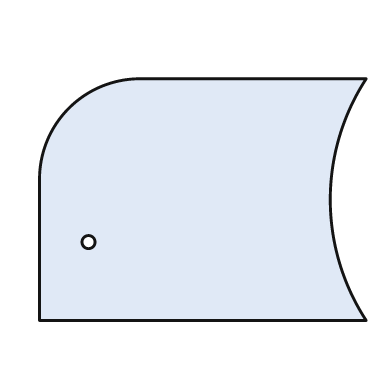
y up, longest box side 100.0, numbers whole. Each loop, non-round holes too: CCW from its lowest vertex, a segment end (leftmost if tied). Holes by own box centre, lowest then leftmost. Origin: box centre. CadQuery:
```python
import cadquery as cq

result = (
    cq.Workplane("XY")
    .moveTo(-50.0, -37.0)
    .lineTo(50.0, -37.0)
    .threePointArc((39.0, 0.0), (50.0, 37.0))
    .lineTo(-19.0, 37.0)
    .threePointArc((-41.0, 28.0), (-50.0, 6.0))
    .close()
    .moveTo(-35.0, -13.0)
    .circle(2.0)
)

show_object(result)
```